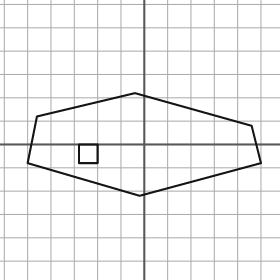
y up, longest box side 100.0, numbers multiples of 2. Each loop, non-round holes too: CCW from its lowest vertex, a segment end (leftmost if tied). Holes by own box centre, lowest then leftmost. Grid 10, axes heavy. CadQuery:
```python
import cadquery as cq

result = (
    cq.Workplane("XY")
    .moveTo(-2.0, -22.0)
    .lineTo(50.0, -8.0)
    .lineTo(46.0, 8.0)
    .lineTo(-4.0, 22.0)
    .lineTo(-46.0, 12.0)
    .lineTo(-50.0, -8.0)
    .close()
    .moveTo(-28.0, -8.0)
    .lineTo(-20.0, -8.0)
    .lineTo(-20.0, 0.0)
    .lineTo(-28.0, 0.0)
    .close()
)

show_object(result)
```